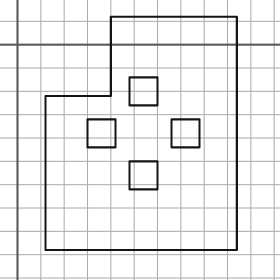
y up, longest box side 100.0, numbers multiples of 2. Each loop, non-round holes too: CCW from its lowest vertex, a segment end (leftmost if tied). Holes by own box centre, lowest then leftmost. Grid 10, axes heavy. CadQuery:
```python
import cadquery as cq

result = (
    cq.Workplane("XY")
    .moveTo(12.0, -88.0)
    .lineTo(94.0, -88.0)
    .lineTo(94.0, 12.0)
    .lineTo(40.0, 12.0)
    .lineTo(40.0, -22.0)
    .lineTo(12.0, -22.0)
    .close()
    .moveTo(48.0, -62.0)
    .lineTo(60.0, -62.0)
    .lineTo(60.0, -50.0)
    .lineTo(48.0, -50.0)
    .close()
    .moveTo(30.0, -44.0)
    .lineTo(42.0, -44.0)
    .lineTo(42.0, -32.0)
    .lineTo(30.0, -32.0)
    .close()
    .moveTo(66.0, -44.0)
    .lineTo(78.0, -44.0)
    .lineTo(78.0, -32.0)
    .lineTo(66.0, -32.0)
    .close()
    .moveTo(48.0, -26.0)
    .lineTo(60.0, -26.0)
    .lineTo(60.0, -14.0)
    .lineTo(48.0, -14.0)
    .close()
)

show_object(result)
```